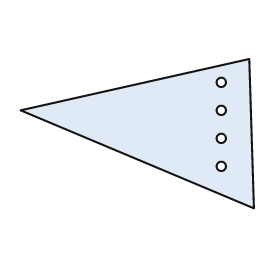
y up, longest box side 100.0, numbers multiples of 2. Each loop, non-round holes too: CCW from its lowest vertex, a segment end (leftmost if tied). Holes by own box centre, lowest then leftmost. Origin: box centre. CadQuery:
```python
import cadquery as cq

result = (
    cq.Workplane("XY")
    .moveTo(50.0, -32.0)
    .lineTo(48.0, 32.0)
    .lineTo(-50.0, 10.0)
    .close()
    .moveTo(36.0, -14.0)
    .circle(2.0)
    .moveTo(36.0, -2.0)
    .circle(2.0)
    .moveTo(36.0, 10.0)
    .circle(2.0)
    .moveTo(36.0, 22.0)
    .circle(2.0)
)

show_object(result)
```